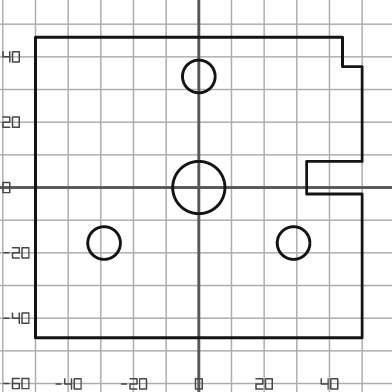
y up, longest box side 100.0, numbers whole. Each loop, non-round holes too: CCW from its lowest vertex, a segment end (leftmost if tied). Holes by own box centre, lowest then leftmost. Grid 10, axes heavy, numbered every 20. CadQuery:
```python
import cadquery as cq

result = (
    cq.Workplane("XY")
    .moveTo(-50.0, -46.0)
    .lineTo(50.0, -46.0)
    .lineTo(50.0, -2.0)
    .lineTo(33.0, -2.0)
    .lineTo(33.0, 8.0)
    .lineTo(50.0, 8.0)
    .lineTo(50.0, 37.0)
    .lineTo(44.0, 37.0)
    .lineTo(44.0, 46.0)
    .lineTo(-50.0, 46.0)
    .close()
    .moveTo(-29.0, -17.0)
    .circle(5.0)
    .moveTo(29.0, -17.0)
    .circle(5.0)
    .moveTo(0.0, 0.0)
    .circle(8.0)
    .moveTo(0.0, 34.0)
    .circle(5.0)
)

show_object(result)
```